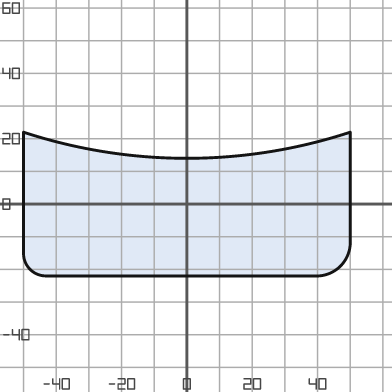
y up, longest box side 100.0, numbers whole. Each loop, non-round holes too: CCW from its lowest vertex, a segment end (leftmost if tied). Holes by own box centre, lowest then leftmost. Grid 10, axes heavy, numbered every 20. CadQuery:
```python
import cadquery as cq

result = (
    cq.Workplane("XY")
    .moveTo(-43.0, -22.0)
    .lineTo(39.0, -22.0)
    .threePointArc((47.0, -19.0), (50.0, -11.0))
    .lineTo(50.0, 22.0)
    .threePointArc((0.0, 14.0), (-50.0, 22.0))
    .lineTo(-50.0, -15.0)
    .threePointArc((-48.0, -20.0), (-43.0, -22.0))
    .close()
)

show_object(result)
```